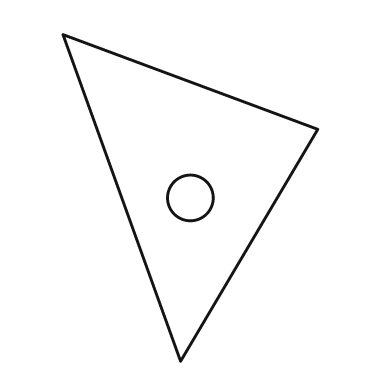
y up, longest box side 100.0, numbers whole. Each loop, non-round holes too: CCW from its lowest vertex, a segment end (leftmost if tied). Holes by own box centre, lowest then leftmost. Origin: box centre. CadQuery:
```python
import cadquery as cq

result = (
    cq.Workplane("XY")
    .moveTo(-3.0, -50.0)
    .lineTo(39.0, 21.0)
    .lineTo(-39.0, 50.0)
    .close()
    .moveTo(0.0, 0.0)
    .circle(7.0)
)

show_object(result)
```